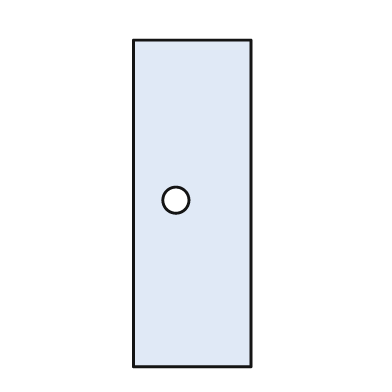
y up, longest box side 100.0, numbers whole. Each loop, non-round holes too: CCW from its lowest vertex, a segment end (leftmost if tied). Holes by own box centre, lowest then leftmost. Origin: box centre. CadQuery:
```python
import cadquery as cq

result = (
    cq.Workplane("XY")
    .moveTo(-18.0, -50.0)
    .lineTo(18.0, -50.0)
    .lineTo(18.0, 50.0)
    .lineTo(-18.0, 50.0)
    .close()
    .moveTo(-5.0, 1.0)
    .circle(4.0)
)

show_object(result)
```